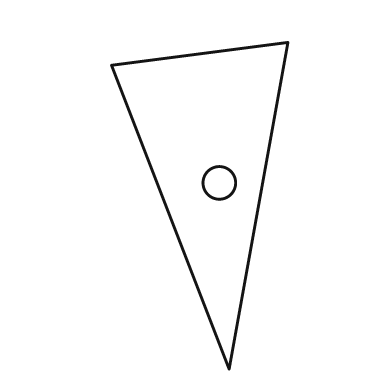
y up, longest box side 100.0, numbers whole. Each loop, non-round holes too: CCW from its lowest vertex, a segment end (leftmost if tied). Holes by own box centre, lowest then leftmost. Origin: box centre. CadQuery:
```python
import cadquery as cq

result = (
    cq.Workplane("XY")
    .moveTo(9.0, -50.0)
    .lineTo(27.0, 50.0)
    .lineTo(-27.0, 43.0)
    .close()
    .moveTo(6.0, 7.0)
    .circle(5.0)
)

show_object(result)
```